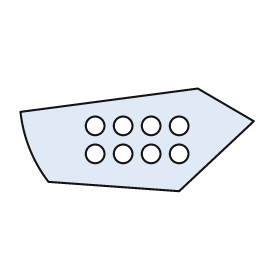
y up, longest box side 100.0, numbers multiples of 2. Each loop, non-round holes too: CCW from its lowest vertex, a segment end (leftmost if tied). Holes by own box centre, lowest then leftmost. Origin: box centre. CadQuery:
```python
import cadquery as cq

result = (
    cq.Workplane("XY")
    .moveTo(18.0, -22.0)
    .lineTo(50.0, 8.0)
    .lineTo(26.0, 22.0)
    .lineTo(-50.0, 12.0)
    .threePointArc((-46.0, -4.0), (-38.0, -18.0))
    .close()
    .moveTo(-18.0, -6.0)
    .circle(4.0)
    .moveTo(-6.0, -6.0)
    .circle(4.0)
    .moveTo(6.0, -6.0)
    .circle(4.0)
    .moveTo(18.0, -6.0)
    .circle(4.0)
    .moveTo(-18.0, 6.0)
    .circle(4.0)
    .moveTo(-6.0, 6.0)
    .circle(4.0)
    .moveTo(6.0, 6.0)
    .circle(4.0)
    .moveTo(18.0, 6.0)
    .circle(4.0)
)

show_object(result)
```